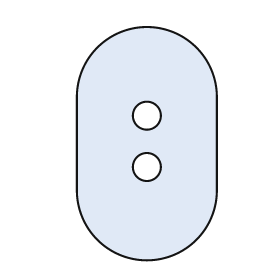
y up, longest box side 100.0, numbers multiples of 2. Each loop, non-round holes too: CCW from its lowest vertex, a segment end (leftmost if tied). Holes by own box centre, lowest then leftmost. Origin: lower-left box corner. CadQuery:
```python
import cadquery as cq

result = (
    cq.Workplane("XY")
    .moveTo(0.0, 30.0)
    .threePointArc((30.0, 0.0), (60.0, 30.0))
    .lineTo(60.0, 70.0)
    .threePointArc((30.0, 100.0), (0.0, 70.0))
    .close()
    .moveTo(30.0, 40.0)
    .circle(6.0)
    .moveTo(30.0, 62.0)
    .circle(6.0)
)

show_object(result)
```